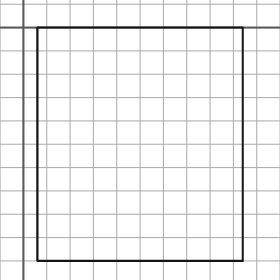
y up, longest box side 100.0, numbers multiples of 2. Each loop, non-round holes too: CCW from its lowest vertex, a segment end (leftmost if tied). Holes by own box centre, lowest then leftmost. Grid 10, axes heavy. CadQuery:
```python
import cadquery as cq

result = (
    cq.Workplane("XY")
    .moveTo(6.0, -100.0)
    .lineTo(94.0, -100.0)
    .lineTo(94.0, 0.0)
    .lineTo(6.0, 0.0)
    .close()
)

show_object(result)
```